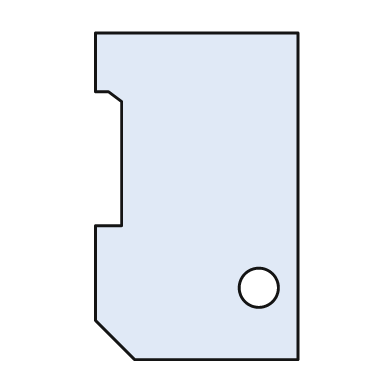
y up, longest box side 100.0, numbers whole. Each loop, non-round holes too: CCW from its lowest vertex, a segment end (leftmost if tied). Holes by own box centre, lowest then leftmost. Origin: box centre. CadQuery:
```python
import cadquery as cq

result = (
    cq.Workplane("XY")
    .moveTo(-19.0, -50.0)
    .lineTo(31.0, -50.0)
    .lineTo(31.0, 50.0)
    .lineTo(-31.0, 50.0)
    .lineTo(-31.0, 32.0)
    .lineTo(-27.0, 32.0)
    .lineTo(-23.0, 29.0)
    .lineTo(-23.0, -9.0)
    .lineTo(-31.0, -9.0)
    .lineTo(-31.0, -38.0)
    .close()
    .moveTo(19.0, -28.0)
    .circle(6.0)
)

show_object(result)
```